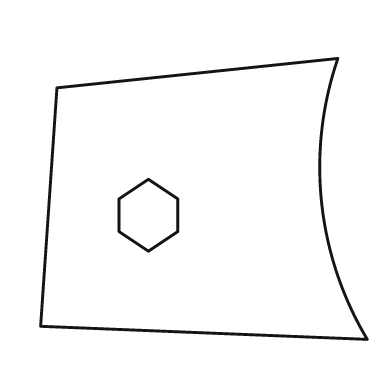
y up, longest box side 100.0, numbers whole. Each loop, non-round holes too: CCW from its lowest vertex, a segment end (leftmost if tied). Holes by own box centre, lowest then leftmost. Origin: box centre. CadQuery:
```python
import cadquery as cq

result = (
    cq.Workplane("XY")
    .moveTo(50.0, -43.0)
    .threePointArc((36.0, -1.0), (41.0, 43.0))
    .lineTo(-45.0, 34.0)
    .lineTo(-50.0, -39.0)
    .close()
    .moveTo(-17.0, -16.0)
    .lineTo(-8.0, -10.0)
    .lineTo(-8.0, 0.0)
    .lineTo(-17.0, 6.0)
    .lineTo(-26.0, 0.0)
    .lineTo(-26.0, -10.0)
    .close()
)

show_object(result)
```